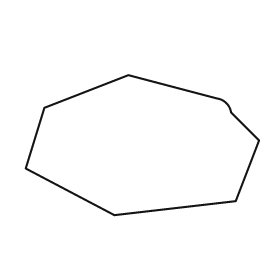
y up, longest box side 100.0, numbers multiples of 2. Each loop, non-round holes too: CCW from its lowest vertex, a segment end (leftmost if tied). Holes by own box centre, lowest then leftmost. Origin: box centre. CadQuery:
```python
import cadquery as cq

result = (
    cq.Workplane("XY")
    .moveTo(-12.0, -30.0)
    .lineTo(40.0, -24.0)
    .lineTo(50.0, 2.0)
    .lineTo(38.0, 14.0)
    .threePointArc((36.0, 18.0), (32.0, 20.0))
    .lineTo(-6.0, 30.0)
    .lineTo(-42.0, 16.0)
    .lineTo(-50.0, -10.0)
    .close()
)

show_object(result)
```